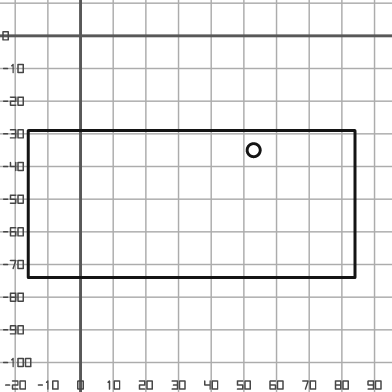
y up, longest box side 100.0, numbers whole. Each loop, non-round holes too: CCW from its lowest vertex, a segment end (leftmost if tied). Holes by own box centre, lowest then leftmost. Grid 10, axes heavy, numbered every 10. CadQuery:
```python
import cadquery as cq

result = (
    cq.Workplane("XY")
    .moveTo(-16.0, -74.0)
    .lineTo(84.0, -74.0)
    .lineTo(84.0, -29.0)
    .lineTo(-16.0, -29.0)
    .close()
    .moveTo(53.0, -35.0)
    .circle(2.0)
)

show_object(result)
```